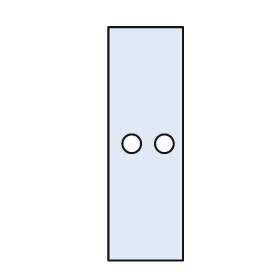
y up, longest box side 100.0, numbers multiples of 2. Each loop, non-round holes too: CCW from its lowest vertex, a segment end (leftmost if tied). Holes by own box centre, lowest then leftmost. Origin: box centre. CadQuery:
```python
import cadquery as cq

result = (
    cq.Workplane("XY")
    .moveTo(-16.0, -50.0)
    .lineTo(16.0, -50.0)
    .lineTo(16.0, 50.0)
    .lineTo(-16.0, 50.0)
    .close()
    .moveTo(-6.0, 0.0)
    .circle(4.0)
    .moveTo(8.0, 0.0)
    .circle(4.0)
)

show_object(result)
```